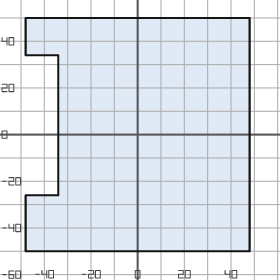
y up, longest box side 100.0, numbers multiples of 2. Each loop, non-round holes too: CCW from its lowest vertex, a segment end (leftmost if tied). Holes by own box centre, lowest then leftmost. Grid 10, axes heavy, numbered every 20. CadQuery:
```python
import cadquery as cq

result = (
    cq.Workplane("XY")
    .moveTo(-48.0, -50.0)
    .lineTo(48.0, -50.0)
    .lineTo(48.0, 50.0)
    .lineTo(-48.0, 50.0)
    .lineTo(-48.0, 34.0)
    .lineTo(-34.0, 34.0)
    .lineTo(-34.0, -26.0)
    .lineTo(-48.0, -26.0)
    .close()
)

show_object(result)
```